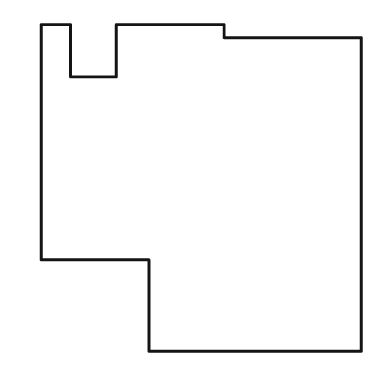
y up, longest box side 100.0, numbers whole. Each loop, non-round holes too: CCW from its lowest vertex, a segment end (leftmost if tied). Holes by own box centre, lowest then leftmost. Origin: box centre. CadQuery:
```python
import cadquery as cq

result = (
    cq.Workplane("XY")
    .moveTo(-16.0, -50.0)
    .lineTo(49.0, -50.0)
    .lineTo(49.0, 46.0)
    .lineTo(7.0, 46.0)
    .lineTo(7.0, 50.0)
    .lineTo(-26.0, 50.0)
    .lineTo(-26.0, 34.0)
    .lineTo(-40.0, 34.0)
    .lineTo(-40.0, 50.0)
    .lineTo(-49.0, 50.0)
    .lineTo(-49.0, -22.0)
    .lineTo(-16.0, -22.0)
    .close()
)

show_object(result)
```